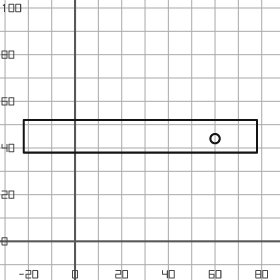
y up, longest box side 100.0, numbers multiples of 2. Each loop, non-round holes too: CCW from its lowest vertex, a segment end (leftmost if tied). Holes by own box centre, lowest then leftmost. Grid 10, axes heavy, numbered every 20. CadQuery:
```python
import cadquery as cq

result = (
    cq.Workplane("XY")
    .moveTo(-22.0, 38.0)
    .lineTo(78.0, 38.0)
    .lineTo(78.0, 52.0)
    .lineTo(-22.0, 52.0)
    .close()
    .moveTo(60.0, 44.0)
    .circle(2.0)
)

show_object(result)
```